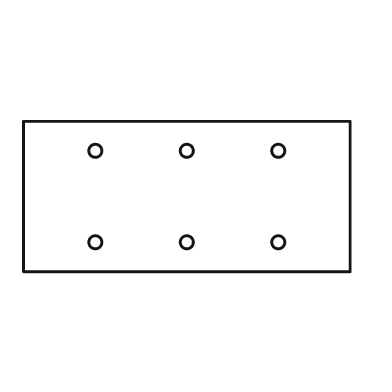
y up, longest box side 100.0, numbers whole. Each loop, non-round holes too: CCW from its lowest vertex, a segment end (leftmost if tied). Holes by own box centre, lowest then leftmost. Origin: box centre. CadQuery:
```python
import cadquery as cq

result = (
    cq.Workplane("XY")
    .moveTo(-50.0, -23.0)
    .lineTo(50.0, -23.0)
    .lineTo(50.0, 23.0)
    .lineTo(-50.0, 23.0)
    .close()
    .moveTo(-28.0, -14.0)
    .circle(2.0)
    .moveTo(0.0, -14.0)
    .circle(2.0)
    .moveTo(28.0, -14.0)
    .circle(2.0)
    .moveTo(-28.0, 14.0)
    .circle(2.0)
    .moveTo(0.0, 14.0)
    .circle(2.0)
    .moveTo(28.0, 14.0)
    .circle(2.0)
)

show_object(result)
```